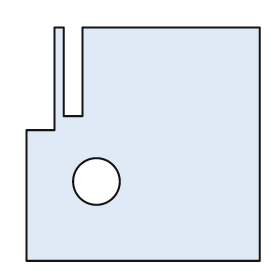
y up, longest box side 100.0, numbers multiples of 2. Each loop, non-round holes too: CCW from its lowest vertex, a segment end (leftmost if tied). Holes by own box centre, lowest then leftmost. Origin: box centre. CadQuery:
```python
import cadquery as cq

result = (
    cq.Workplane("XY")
    .moveTo(-50.0, -50.0)
    .lineTo(50.0, -50.0)
    .lineTo(50.0, 50.0)
    .lineTo(-26.0, 50.0)
    .lineTo(-26.0, 12.0)
    .lineTo(-34.0, 12.0)
    .lineTo(-34.0, 50.0)
    .lineTo(-38.0, 50.0)
    .lineTo(-38.0, 6.0)
    .lineTo(-50.0, 6.0)
    .close()
    .moveTo(-20.0, -16.0)
    .circle(10.0)
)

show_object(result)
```